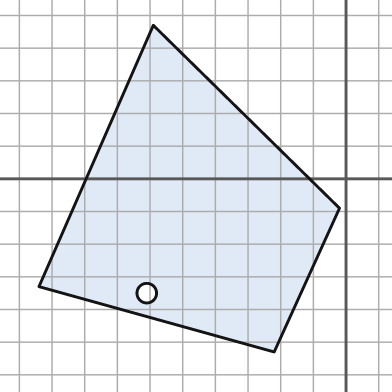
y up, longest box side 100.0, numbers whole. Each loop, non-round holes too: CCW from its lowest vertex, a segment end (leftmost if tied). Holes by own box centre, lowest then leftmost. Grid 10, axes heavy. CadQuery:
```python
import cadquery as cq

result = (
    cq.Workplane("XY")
    .moveTo(-22.0, -53.0)
    .lineTo(-2.0, -9.0)
    .lineTo(-59.0, 47.0)
    .lineTo(-94.0, -33.0)
    .close()
    .moveTo(-61.0, -35.0)
    .circle(3.0)
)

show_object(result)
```